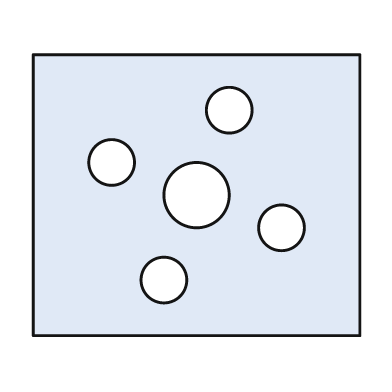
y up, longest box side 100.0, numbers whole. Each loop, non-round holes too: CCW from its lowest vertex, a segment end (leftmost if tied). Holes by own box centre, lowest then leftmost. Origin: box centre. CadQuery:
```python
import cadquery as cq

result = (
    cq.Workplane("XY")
    .moveTo(-50.0, -43.0)
    .lineTo(50.0, -43.0)
    .lineTo(50.0, 43.0)
    .lineTo(-50.0, 43.0)
    .close()
    .moveTo(-10.0, -26.0)
    .circle(7.0)
    .moveTo(26.0, -10.0)
    .circle(7.0)
    .moveTo(0.0, 0.0)
    .circle(10.0)
    .moveTo(-26.0, 10.0)
    .circle(7.0)
    .moveTo(10.0, 26.0)
    .circle(7.0)
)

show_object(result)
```